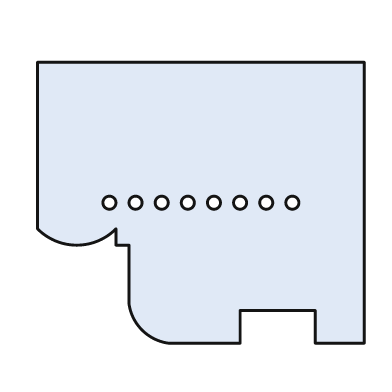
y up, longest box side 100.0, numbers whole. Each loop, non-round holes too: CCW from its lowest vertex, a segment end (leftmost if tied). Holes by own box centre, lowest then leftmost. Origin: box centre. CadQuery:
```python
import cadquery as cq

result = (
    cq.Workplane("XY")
    .moveTo(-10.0, -43.0)
    .lineTo(12.0, -43.0)
    .lineTo(12.0, -33.0)
    .lineTo(35.0, -33.0)
    .lineTo(35.0, -43.0)
    .lineTo(50.0, -43.0)
    .lineTo(50.0, 43.0)
    .lineTo(-50.0, 43.0)
    .lineTo(-50.0, -8.0)
    .threePointArc((-38.0, -13.0), (-26.0, -8.0))
    .lineTo(-26.0, -13.0)
    .lineTo(-22.0, -13.0)
    .lineTo(-22.0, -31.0)
    .threePointArc((-18.0, -39.0), (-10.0, -43.0))
    .close()
    .moveTo(-28.0, 0.0)
    .circle(2.0)
    .moveTo(-20.0, 0.0)
    .circle(2.0)
    .moveTo(-12.0, 0.0)
    .circle(2.0)
    .moveTo(-4.0, 0.0)
    .circle(2.0)
    .moveTo(4.0, 0.0)
    .circle(2.0)
    .moveTo(12.0, 0.0)
    .circle(2.0)
    .moveTo(20.0, 0.0)
    .circle(2.0)
    .moveTo(28.0, 0.0)
    .circle(2.0)
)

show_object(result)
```